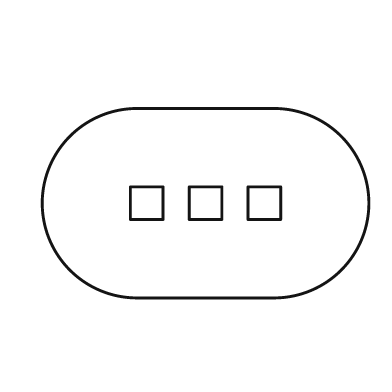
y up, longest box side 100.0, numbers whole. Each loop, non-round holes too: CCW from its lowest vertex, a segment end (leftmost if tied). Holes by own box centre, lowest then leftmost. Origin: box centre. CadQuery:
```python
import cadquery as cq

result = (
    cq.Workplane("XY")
    .moveTo(-21.0, -29.0)
    .lineTo(21.0, -29.0)
    .threePointArc((50.0, 0.0), (21.0, 29.0))
    .lineTo(-21.0, 29.0)
    .threePointArc((-50.0, 0.0), (-21.0, -29.0))
    .close()
    .moveTo(-23.0, -5.0)
    .lineTo(-13.0, -5.0)
    .lineTo(-13.0, 5.0)
    .lineTo(-23.0, 5.0)
    .close()
    .moveTo(-5.0, -5.0)
    .lineTo(5.0, -5.0)
    .lineTo(5.0, 5.0)
    .lineTo(-5.0, 5.0)
    .close()
    .moveTo(13.0, -5.0)
    .lineTo(23.0, -5.0)
    .lineTo(23.0, 5.0)
    .lineTo(13.0, 5.0)
    .close()
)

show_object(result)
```